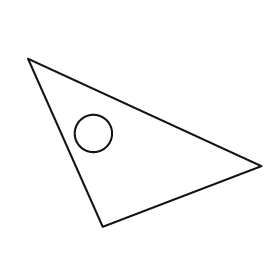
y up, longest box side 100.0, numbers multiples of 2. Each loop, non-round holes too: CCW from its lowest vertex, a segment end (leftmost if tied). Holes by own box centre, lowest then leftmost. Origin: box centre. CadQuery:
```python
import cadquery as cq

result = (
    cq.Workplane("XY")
    .moveTo(-18.0, -36.0)
    .lineTo(50.0, -10.0)
    .lineTo(-50.0, 36.0)
    .close()
    .moveTo(-22.0, 4.0)
    .circle(8.0)
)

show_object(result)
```